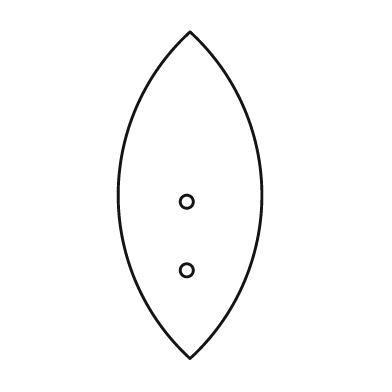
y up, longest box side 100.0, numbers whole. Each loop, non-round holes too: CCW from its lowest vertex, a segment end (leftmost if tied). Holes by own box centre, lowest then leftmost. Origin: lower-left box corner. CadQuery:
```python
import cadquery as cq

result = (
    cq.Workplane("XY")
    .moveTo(22.0, 0.0)
    .threePointArc((44.0, 50.0), (22.0, 100.0))
    .threePointArc((0.0, 50.0), (22.0, 0.0))
    .close()
    .moveTo(21.0, 27.0)
    .circle(2.0)
    .moveTo(21.0, 48.0)
    .circle(2.0)
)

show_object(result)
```